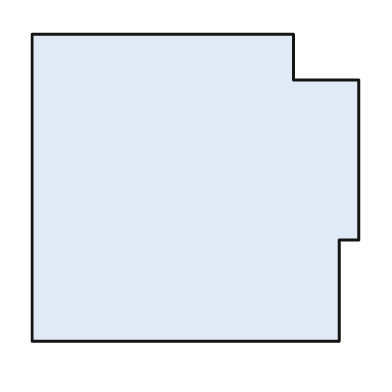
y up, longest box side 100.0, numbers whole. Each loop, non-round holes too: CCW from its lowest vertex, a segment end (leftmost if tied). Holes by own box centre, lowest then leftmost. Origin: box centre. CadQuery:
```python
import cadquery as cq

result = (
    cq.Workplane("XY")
    .moveTo(-50.0, -47.0)
    .lineTo(44.0, -47.0)
    .lineTo(44.0, -16.0)
    .lineTo(50.0, -16.0)
    .lineTo(50.0, 33.0)
    .lineTo(30.0, 33.0)
    .lineTo(30.0, 47.0)
    .lineTo(-50.0, 47.0)
    .close()
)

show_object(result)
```